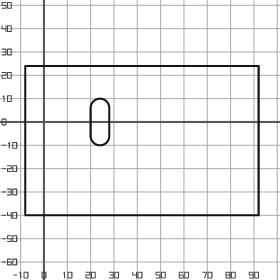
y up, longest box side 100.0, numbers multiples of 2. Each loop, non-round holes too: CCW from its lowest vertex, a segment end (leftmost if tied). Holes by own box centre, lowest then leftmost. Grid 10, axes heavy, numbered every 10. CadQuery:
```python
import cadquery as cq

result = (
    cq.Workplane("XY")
    .moveTo(-8.0, -40.0)
    .lineTo(92.0, -40.0)
    .lineTo(92.0, 24.0)
    .lineTo(-8.0, 24.0)
    .close()
    .moveTo(20.0, -6.0)
    .threePointArc((24.0, -10.0), (28.0, -6.0))
    .lineTo(28.0, 6.0)
    .threePointArc((24.0, 10.0), (20.0, 6.0))
    .close()
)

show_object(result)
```